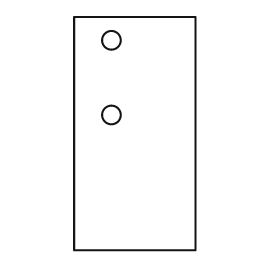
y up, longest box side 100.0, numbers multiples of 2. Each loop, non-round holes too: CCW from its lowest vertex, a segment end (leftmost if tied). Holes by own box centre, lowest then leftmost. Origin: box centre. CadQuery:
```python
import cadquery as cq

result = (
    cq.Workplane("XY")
    .moveTo(-26.0, -50.0)
    .lineTo(26.0, -50.0)
    .lineTo(26.0, 50.0)
    .lineTo(-26.0, 50.0)
    .close()
    .moveTo(-10.0, 8.0)
    .circle(4.0)
    .moveTo(-10.0, 40.0)
    .circle(4.0)
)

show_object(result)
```